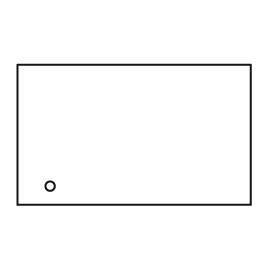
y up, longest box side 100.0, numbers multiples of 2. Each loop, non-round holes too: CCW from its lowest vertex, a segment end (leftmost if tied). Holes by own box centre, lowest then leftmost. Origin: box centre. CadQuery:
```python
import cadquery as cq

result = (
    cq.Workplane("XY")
    .moveTo(-50.0, -30.0)
    .lineTo(50.0, -30.0)
    .lineTo(50.0, 30.0)
    .lineTo(-50.0, 30.0)
    .close()
    .moveTo(-36.0, -22.0)
    .circle(2.0)
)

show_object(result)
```